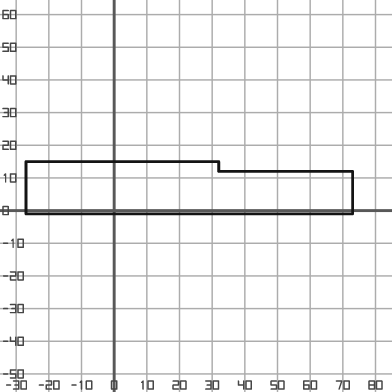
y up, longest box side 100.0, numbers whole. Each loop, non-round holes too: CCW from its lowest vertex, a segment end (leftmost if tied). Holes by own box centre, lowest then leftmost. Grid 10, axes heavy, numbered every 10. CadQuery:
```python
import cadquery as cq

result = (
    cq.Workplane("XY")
    .moveTo(-27.0, -1.0)
    .lineTo(73.0, -1.0)
    .lineTo(73.0, 12.0)
    .lineTo(32.0, 12.0)
    .lineTo(32.0, 15.0)
    .lineTo(-27.0, 15.0)
    .close()
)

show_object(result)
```